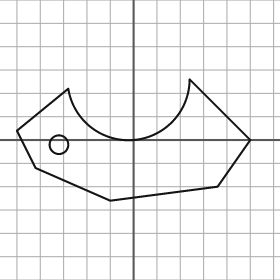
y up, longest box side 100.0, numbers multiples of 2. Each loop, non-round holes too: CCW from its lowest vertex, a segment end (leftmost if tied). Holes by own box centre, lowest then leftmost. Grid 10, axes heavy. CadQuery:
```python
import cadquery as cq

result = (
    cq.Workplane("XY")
    .moveTo(-10.0, -26.0)
    .lineTo(36.0, -20.0)
    .lineTo(50.0, 0.0)
    .lineTo(24.0, 26.0)
    .threePointArc((0.0, 0.0), (-28.0, 22.0))
    .lineTo(-50.0, 4.0)
    .lineTo(-42.0, -12.0)
    .close()
    .moveTo(-32.0, -2.0)
    .circle(4.0)
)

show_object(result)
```